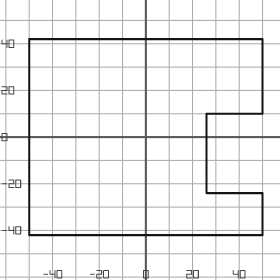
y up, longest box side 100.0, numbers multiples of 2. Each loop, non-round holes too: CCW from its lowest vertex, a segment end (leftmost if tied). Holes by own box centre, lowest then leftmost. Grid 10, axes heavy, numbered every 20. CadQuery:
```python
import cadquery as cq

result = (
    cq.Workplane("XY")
    .moveTo(-50.0, -42.0)
    .lineTo(50.0, -42.0)
    .lineTo(50.0, -24.0)
    .lineTo(26.0, -24.0)
    .lineTo(26.0, 10.0)
    .lineTo(50.0, 10.0)
    .lineTo(50.0, 42.0)
    .lineTo(-50.0, 42.0)
    .close()
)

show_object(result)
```